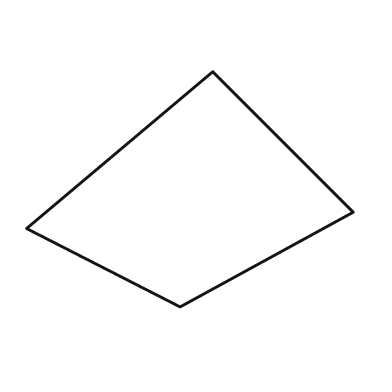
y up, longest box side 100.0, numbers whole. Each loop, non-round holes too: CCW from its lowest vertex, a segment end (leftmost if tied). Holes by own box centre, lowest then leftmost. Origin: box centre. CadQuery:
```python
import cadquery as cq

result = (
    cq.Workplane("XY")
    .moveTo(-3.0, -36.0)
    .lineTo(50.0, -7.0)
    .lineTo(7.0, 36.0)
    .lineTo(-50.0, -12.0)
    .close()
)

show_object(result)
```